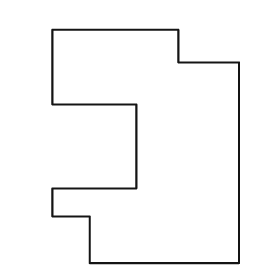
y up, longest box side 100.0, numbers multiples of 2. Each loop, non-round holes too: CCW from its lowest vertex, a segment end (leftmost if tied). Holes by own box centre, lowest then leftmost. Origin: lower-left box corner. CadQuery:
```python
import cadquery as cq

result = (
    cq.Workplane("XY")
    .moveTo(16.0, 0.0)
    .lineTo(80.0, 0.0)
    .lineTo(80.0, 86.0)
    .lineTo(54.0, 86.0)
    .lineTo(54.0, 100.0)
    .lineTo(0.0, 100.0)
    .lineTo(0.0, 68.0)
    .lineTo(36.0, 68.0)
    .lineTo(36.0, 32.0)
    .lineTo(0.0, 32.0)
    .lineTo(0.0, 20.0)
    .lineTo(16.0, 20.0)
    .close()
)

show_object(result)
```